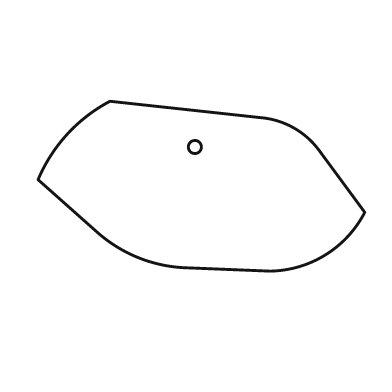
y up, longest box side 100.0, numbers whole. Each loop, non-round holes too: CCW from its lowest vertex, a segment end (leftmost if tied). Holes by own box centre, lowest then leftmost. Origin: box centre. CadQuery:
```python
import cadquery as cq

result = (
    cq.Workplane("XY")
    .moveTo(21.0, -26.0)
    .threePointArc((38.0, -21.0), (50.0, -8.0))
    .lineTo(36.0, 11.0)
    .threePointArc((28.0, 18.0), (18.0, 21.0))
    .lineTo(-28.0, 26.0)
    .threePointArc((-41.0, 16.0), (-50.0, 2.0))
    .lineTo(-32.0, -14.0)
    .threePointArc((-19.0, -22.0), (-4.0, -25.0))
    .close()
    .moveTo(-2.0, 12.0)
    .circle(2.0)
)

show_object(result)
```